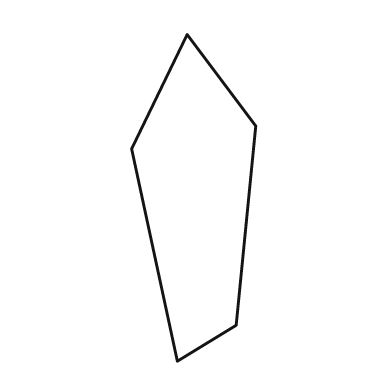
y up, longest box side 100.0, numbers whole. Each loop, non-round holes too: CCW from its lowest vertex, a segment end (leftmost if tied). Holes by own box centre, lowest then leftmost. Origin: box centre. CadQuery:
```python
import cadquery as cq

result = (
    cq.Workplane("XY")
    .moveTo(-5.0, -50.0)
    .lineTo(13.0, -39.0)
    .lineTo(19.0, 22.0)
    .lineTo(-2.0, 50.0)
    .lineTo(-19.0, 15.0)
    .close()
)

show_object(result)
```